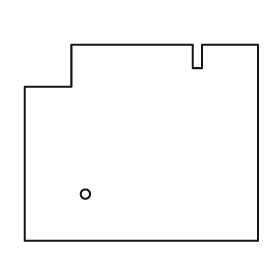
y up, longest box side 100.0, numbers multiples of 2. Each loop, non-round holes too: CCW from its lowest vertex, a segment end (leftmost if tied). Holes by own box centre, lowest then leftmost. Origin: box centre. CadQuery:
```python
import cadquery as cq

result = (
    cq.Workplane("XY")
    .moveTo(-50.0, -42.0)
    .lineTo(50.0, -42.0)
    .lineTo(50.0, 42.0)
    .lineTo(26.0, 42.0)
    .lineTo(26.0, 32.0)
    .lineTo(22.0, 32.0)
    .lineTo(22.0, 42.0)
    .lineTo(-30.0, 42.0)
    .lineTo(-30.0, 24.0)
    .lineTo(-50.0, 24.0)
    .close()
    .moveTo(-24.0, -22.0)
    .circle(2.0)
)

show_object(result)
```